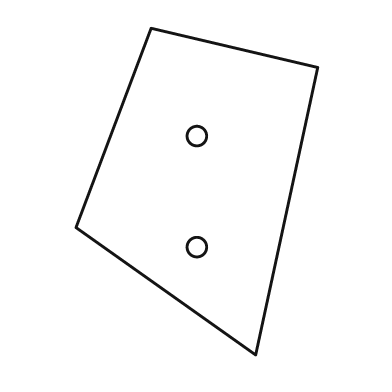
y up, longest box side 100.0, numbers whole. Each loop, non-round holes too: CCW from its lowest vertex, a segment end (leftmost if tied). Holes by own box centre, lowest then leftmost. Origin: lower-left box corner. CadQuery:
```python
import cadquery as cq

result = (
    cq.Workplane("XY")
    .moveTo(55.0, 0.0)
    .lineTo(74.0, 88.0)
    .lineTo(23.0, 100.0)
    .lineTo(0.0, 39.0)
    .close()
    .moveTo(37.0, 33.0)
    .circle(3.0)
    .moveTo(37.0, 67.0)
    .circle(3.0)
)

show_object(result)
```